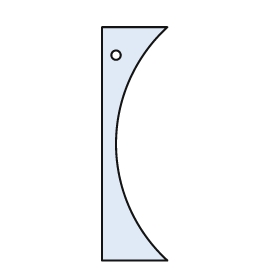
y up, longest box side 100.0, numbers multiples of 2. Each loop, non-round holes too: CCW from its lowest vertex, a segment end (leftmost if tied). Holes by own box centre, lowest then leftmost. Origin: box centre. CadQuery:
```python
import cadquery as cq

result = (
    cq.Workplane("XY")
    .moveTo(-14.0, -50.0)
    .lineTo(14.0, -50.0)
    .threePointArc((-8.0, 0.0), (14.0, 50.0))
    .lineTo(-14.0, 50.0)
    .close()
    .moveTo(-8.0, 38.0)
    .circle(2.0)
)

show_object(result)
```